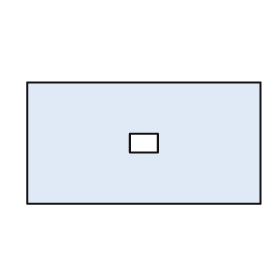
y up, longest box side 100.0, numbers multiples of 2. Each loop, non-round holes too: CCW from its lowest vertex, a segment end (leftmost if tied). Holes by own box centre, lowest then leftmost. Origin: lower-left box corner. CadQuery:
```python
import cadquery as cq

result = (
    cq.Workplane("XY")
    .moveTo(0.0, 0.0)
    .lineTo(100.0, 0.0)
    .lineTo(100.0, 52.0)
    .lineTo(0.0, 52.0)
    .close()
    .moveTo(44.0, 22.0)
    .lineTo(56.0, 22.0)
    .lineTo(56.0, 30.0)
    .lineTo(44.0, 30.0)
    .close()
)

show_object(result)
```